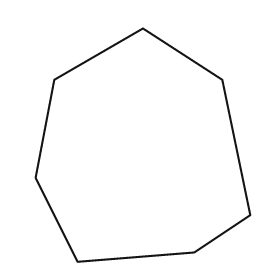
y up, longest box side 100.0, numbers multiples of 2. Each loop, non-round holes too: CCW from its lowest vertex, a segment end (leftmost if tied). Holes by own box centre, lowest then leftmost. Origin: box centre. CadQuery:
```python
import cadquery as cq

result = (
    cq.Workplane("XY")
    .moveTo(-28.0, -50.0)
    .lineTo(22.0, -46.0)
    .lineTo(46.0, -30.0)
    .lineTo(34.0, 28.0)
    .lineTo(0.0, 50.0)
    .lineTo(-38.0, 28.0)
    .lineTo(-46.0, -14.0)
    .close()
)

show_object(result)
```